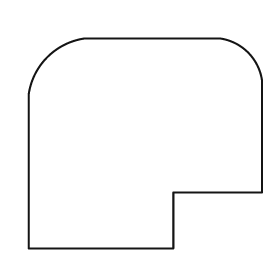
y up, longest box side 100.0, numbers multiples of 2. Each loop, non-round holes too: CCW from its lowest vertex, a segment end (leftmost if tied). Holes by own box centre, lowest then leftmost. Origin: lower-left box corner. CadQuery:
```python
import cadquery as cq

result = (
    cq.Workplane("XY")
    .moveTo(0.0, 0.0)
    .lineTo(62.0, 0.0)
    .lineTo(62.0, 24.0)
    .lineTo(100.0, 24.0)
    .lineTo(100.0, 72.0)
    .threePointArc((94.0, 84.0), (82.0, 90.0))
    .lineTo(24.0, 90.0)
    .threePointArc((8.0, 82.0), (0.0, 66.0))
    .close()
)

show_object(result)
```